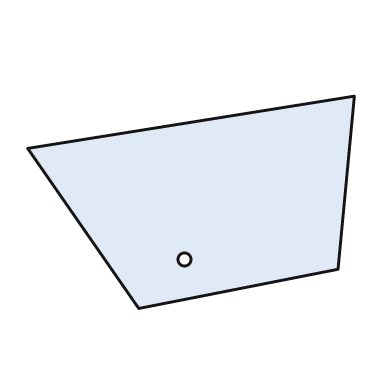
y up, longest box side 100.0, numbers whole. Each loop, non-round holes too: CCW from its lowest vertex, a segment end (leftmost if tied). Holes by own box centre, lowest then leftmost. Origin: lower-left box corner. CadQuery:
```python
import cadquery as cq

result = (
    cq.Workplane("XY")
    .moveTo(34.0, 0.0)
    .lineTo(95.0, 12.0)
    .lineTo(100.0, 65.0)
    .lineTo(0.0, 49.0)
    .close()
    .moveTo(48.0, 15.0)
    .circle(2.0)
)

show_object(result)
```